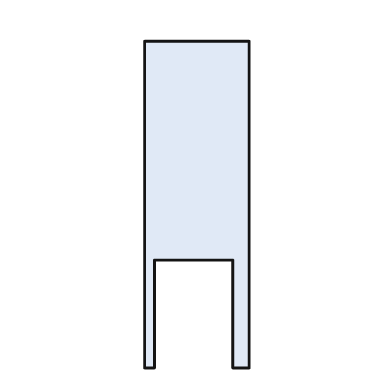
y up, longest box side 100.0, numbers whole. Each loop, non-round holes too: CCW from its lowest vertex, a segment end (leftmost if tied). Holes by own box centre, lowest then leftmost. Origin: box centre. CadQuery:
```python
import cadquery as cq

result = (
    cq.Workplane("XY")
    .moveTo(-16.0, -50.0)
    .lineTo(-13.0, -50.0)
    .lineTo(-13.0, -17.0)
    .lineTo(11.0, -17.0)
    .lineTo(11.0, -50.0)
    .lineTo(16.0, -50.0)
    .lineTo(16.0, 50.0)
    .lineTo(-16.0, 50.0)
    .close()
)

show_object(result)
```